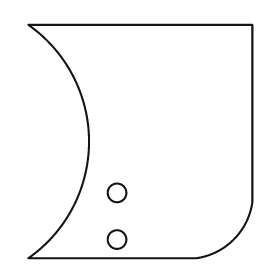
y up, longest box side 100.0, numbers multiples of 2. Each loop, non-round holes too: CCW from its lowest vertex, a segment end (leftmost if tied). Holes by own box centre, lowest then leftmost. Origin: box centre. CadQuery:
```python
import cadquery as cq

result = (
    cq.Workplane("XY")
    .moveTo(-48.0, -50.0)
    .lineTo(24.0, -50.0)
    .threePointArc((40.0, -42.0), (48.0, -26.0))
    .lineTo(48.0, 50.0)
    .lineTo(-48.0, 50.0)
    .threePointArc((-22.0, 0.0), (-48.0, -50.0))
    .close()
    .moveTo(-10.0, -42.0)
    .circle(4.0)
    .moveTo(-10.0, -22.0)
    .circle(4.0)
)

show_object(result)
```